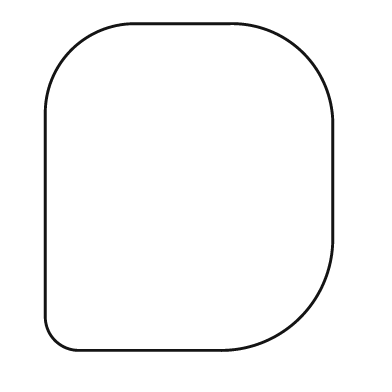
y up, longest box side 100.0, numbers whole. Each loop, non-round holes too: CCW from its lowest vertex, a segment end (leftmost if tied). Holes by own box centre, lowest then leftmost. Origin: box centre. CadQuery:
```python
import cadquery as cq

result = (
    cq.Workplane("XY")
    .moveTo(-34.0, -50.0)
    .lineTo(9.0, -50.0)
    .threePointArc((34.0, -40.0), (44.0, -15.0))
    .lineTo(44.0, 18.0)
    .threePointArc((35.0, 41.0), (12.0, 50.0))
    .lineTo(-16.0, 50.0)
    .threePointArc((-36.0, 42.0), (-44.0, 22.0))
    .lineTo(-44.0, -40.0)
    .threePointArc((-41.0, -47.0), (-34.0, -50.0))
    .close()
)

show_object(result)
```